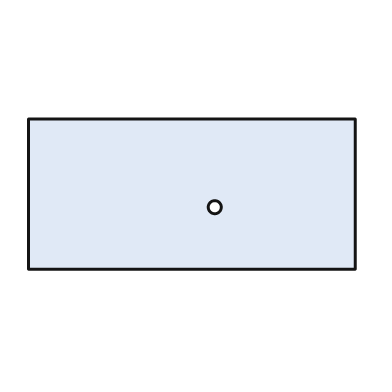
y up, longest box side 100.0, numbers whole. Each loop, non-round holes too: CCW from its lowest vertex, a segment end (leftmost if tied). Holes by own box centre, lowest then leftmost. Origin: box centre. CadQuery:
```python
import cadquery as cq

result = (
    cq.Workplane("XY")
    .moveTo(-50.0, -23.0)
    .lineTo(50.0, -23.0)
    .lineTo(50.0, 23.0)
    .lineTo(-50.0, 23.0)
    .close()
    .moveTo(7.0, -4.0)
    .circle(2.0)
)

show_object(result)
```